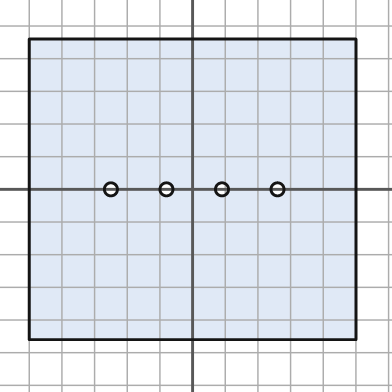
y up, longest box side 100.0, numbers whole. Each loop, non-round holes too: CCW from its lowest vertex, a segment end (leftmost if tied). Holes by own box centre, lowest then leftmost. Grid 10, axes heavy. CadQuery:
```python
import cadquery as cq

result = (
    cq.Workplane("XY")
    .moveTo(-50.0, -46.0)
    .lineTo(50.0, -46.0)
    .lineTo(50.0, 46.0)
    .lineTo(-50.0, 46.0)
    .close()
    .moveTo(-25.0, 0.0)
    .circle(2.0)
    .moveTo(-8.0, 0.0)
    .circle(2.0)
    .moveTo(9.0, 0.0)
    .circle(2.0)
    .moveTo(26.0, 0.0)
    .circle(2.0)
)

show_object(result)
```